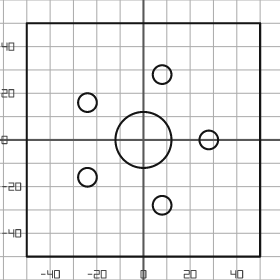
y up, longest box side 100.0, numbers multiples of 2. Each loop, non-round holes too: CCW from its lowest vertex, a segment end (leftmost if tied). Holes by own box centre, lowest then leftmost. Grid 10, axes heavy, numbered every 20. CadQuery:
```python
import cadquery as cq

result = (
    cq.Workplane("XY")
    .moveTo(-50.0, -50.0)
    .lineTo(50.0, -50.0)
    .lineTo(50.0, 50.0)
    .lineTo(-50.0, 50.0)
    .close()
    .moveTo(8.0, -28.0)
    .circle(4.0)
    .moveTo(-24.0, -16.0)
    .circle(4.0)
    .moveTo(0.0, 0.0)
    .circle(12.0)
    .moveTo(28.0, 0.0)
    .circle(4.0)
    .moveTo(-24.0, 16.0)
    .circle(4.0)
    .moveTo(8.0, 28.0)
    .circle(4.0)
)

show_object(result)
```